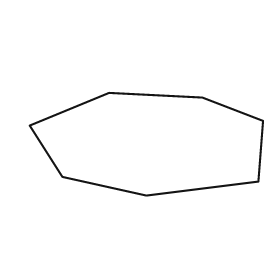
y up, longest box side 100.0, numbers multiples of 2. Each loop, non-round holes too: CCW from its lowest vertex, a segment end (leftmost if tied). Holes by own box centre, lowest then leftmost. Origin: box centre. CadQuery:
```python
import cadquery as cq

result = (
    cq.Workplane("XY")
    .moveTo(0.0, -22.0)
    .lineTo(48.0, -16.0)
    .lineTo(50.0, 10.0)
    .lineTo(24.0, 20.0)
    .lineTo(-16.0, 22.0)
    .lineTo(-50.0, 8.0)
    .lineTo(-36.0, -14.0)
    .close()
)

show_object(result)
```